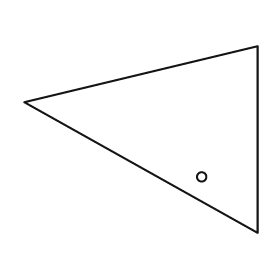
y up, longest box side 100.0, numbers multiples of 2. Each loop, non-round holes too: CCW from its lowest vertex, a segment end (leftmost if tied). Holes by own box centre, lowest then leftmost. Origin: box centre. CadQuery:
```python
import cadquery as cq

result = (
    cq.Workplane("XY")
    .moveTo(50.0, -40.0)
    .lineTo(50.0, 40.0)
    .lineTo(-50.0, 16.0)
    .close()
    .moveTo(26.0, -16.0)
    .circle(2.0)
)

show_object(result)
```